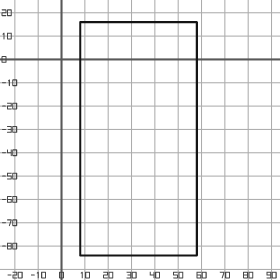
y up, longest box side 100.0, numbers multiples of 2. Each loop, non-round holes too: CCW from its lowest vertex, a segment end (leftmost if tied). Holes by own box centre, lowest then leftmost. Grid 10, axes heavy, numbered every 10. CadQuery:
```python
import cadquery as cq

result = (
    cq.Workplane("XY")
    .moveTo(8.0, -84.0)
    .lineTo(58.0, -84.0)
    .lineTo(58.0, 16.0)
    .lineTo(8.0, 16.0)
    .close()
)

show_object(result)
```